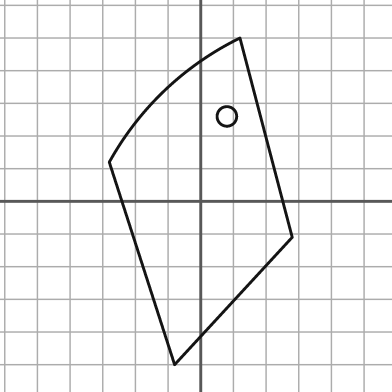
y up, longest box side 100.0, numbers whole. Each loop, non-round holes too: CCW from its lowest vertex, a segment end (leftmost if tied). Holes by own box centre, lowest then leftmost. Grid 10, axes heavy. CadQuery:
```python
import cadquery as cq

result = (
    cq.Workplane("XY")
    .moveTo(-8.0, -50.0)
    .lineTo(28.0, -11.0)
    .lineTo(12.0, 50.0)
    .threePointArc((-11.0, 34.0), (-28.0, 12.0))
    .close()
    .moveTo(8.0, 26.0)
    .circle(3.0)
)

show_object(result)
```